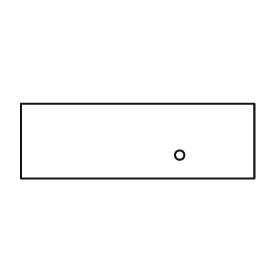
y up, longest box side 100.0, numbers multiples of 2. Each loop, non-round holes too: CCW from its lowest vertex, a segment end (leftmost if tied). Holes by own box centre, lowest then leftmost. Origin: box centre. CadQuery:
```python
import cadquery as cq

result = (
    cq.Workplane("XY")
    .moveTo(-50.0, -16.0)
    .lineTo(50.0, -16.0)
    .lineTo(50.0, 16.0)
    .lineTo(-50.0, 16.0)
    .close()
    .moveTo(18.0, -6.0)
    .circle(2.0)
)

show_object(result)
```